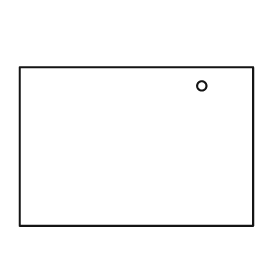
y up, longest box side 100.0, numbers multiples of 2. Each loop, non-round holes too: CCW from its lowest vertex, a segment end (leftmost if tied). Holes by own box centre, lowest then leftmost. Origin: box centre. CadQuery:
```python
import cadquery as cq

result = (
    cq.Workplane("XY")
    .moveTo(-50.0, -34.0)
    .lineTo(50.0, -34.0)
    .lineTo(50.0, 34.0)
    .lineTo(-50.0, 34.0)
    .close()
    .moveTo(28.0, 26.0)
    .circle(2.0)
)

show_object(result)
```